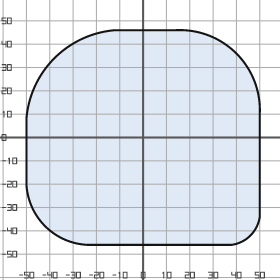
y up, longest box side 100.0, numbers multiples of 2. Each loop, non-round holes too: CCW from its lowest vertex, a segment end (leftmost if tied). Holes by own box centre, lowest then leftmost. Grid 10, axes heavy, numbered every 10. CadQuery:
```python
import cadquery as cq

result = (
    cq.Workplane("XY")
    .moveTo(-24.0, -46.0)
    .lineTo(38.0, -46.0)
    .threePointArc((46.0, -42.0), (50.0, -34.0))
    .lineTo(50.0, 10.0)
    .threePointArc((40.0, 36.0), (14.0, 46.0))
    .lineTo(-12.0, 46.0)
    .threePointArc((-38.0, 34.0), (-50.0, 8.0))
    .lineTo(-50.0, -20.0)
    .threePointArc((-42.0, -38.0), (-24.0, -46.0))
    .close()
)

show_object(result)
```